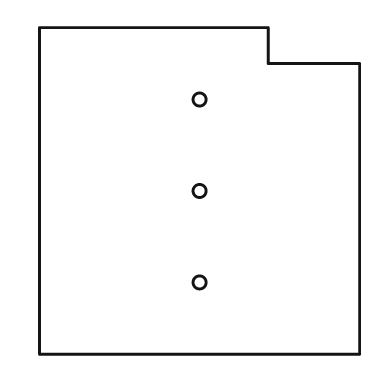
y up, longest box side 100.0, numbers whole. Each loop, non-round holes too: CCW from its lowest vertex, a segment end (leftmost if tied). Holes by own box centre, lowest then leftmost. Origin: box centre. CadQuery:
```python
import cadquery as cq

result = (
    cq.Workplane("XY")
    .moveTo(-49.0, -50.0)
    .lineTo(49.0, -50.0)
    .lineTo(49.0, 39.0)
    .lineTo(21.0, 39.0)
    .lineTo(21.0, 50.0)
    .lineTo(-49.0, 50.0)
    .close()
    .moveTo(0.0, -28.0)
    .circle(2.0)
    .moveTo(0.0, 0.0)
    .circle(2.0)
    .moveTo(0.0, 28.0)
    .circle(2.0)
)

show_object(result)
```